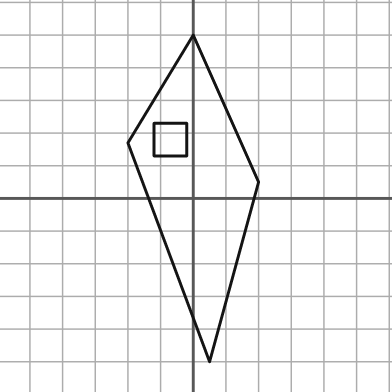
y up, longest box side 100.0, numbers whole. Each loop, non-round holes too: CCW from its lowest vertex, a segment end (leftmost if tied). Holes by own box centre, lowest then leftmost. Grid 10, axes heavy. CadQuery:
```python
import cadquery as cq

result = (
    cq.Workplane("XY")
    .moveTo(5.0, -50.0)
    .lineTo(20.0, 5.0)
    .lineTo(0.0, 50.0)
    .lineTo(-20.0, 17.0)
    .close()
    .moveTo(-12.0, 13.0)
    .lineTo(-2.0, 13.0)
    .lineTo(-2.0, 23.0)
    .lineTo(-12.0, 23.0)
    .close()
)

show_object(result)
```